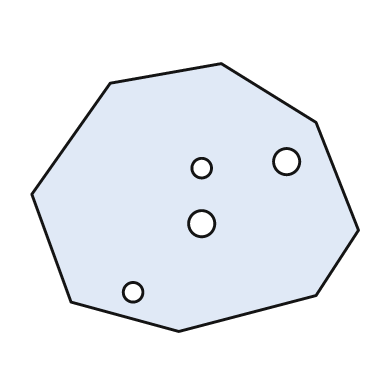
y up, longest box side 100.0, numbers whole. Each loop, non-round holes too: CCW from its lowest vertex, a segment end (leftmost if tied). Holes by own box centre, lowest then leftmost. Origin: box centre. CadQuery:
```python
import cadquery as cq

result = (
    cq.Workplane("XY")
    .moveTo(-5.0, -41.0)
    .lineTo(37.0, -30.0)
    .lineTo(50.0, -10.0)
    .lineTo(37.0, 23.0)
    .lineTo(8.0, 41.0)
    .lineTo(-26.0, 35.0)
    .lineTo(-50.0, 1.0)
    .lineTo(-38.0, -32.0)
    .close()
    .moveTo(-19.0, -29.0)
    .circle(3.0)
    .moveTo(2.0, -8.0)
    .circle(4.0)
    .moveTo(2.0, 9.0)
    .circle(3.0)
    .moveTo(28.0, 11.0)
    .circle(4.0)
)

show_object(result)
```